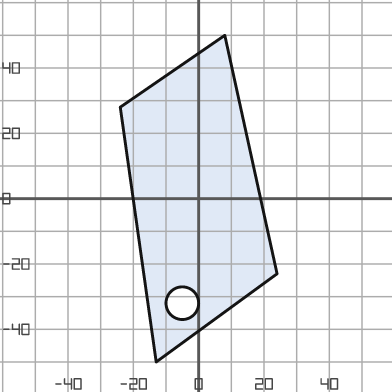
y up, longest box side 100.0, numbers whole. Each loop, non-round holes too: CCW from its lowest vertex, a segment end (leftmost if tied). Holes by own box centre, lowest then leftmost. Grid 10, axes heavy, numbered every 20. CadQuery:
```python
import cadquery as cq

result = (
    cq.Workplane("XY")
    .moveTo(-13.0, -50.0)
    .lineTo(24.0, -23.0)
    .lineTo(8.0, 50.0)
    .lineTo(-24.0, 28.0)
    .close()
    .moveTo(-5.0, -32.0)
    .circle(5.0)
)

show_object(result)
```